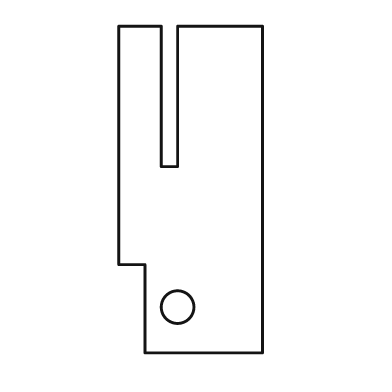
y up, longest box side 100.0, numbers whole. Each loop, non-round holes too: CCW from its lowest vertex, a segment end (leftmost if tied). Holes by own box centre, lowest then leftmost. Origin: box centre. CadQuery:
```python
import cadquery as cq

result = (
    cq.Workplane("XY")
    .moveTo(-14.0, -50.0)
    .lineTo(22.0, -50.0)
    .lineTo(22.0, 50.0)
    .lineTo(-4.0, 50.0)
    .lineTo(-4.0, 7.0)
    .lineTo(-9.0, 7.0)
    .lineTo(-9.0, 50.0)
    .lineTo(-22.0, 50.0)
    .lineTo(-22.0, -23.0)
    .lineTo(-14.0, -23.0)
    .close()
    .moveTo(-4.0, -36.0)
    .circle(5.0)
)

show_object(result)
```